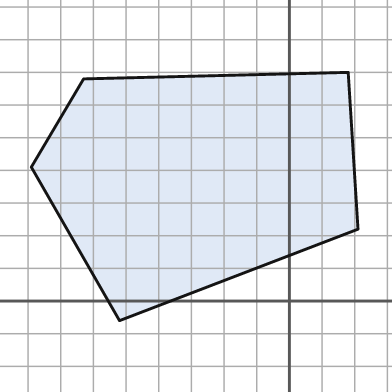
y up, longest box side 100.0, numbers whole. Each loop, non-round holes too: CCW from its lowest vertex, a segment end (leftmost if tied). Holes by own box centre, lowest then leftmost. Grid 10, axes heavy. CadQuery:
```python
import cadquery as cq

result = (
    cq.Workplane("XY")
    .moveTo(-52.0, -6.0)
    .lineTo(21.0, 22.0)
    .lineTo(18.0, 70.0)
    .lineTo(-63.0, 68.0)
    .lineTo(-79.0, 41.0)
    .close()
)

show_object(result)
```